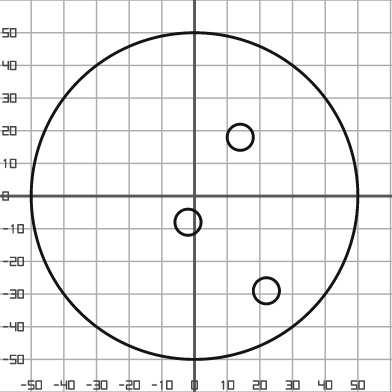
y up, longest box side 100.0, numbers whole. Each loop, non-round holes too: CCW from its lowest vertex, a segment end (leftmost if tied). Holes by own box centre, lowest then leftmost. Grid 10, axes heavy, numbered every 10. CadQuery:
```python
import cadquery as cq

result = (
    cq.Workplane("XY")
    .moveTo(0.0, 0.0)
    .circle(50.0)
    .moveTo(22.0, -29.0)
    .circle(4.0)
    .moveTo(-2.0, -8.0)
    .circle(4.0)
    .moveTo(14.0, 18.0)
    .circle(4.0)
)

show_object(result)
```